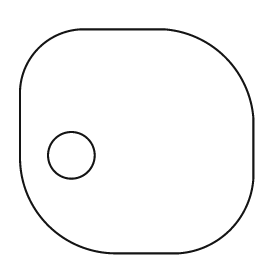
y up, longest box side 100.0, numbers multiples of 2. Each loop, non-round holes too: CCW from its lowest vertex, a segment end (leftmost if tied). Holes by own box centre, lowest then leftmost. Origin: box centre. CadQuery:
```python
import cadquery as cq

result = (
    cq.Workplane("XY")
    .moveTo(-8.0, -48.0)
    .lineTo(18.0, -48.0)
    .threePointArc((40.0, -38.0), (50.0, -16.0))
    .lineTo(50.0, 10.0)
    .threePointArc((38.0, 36.0), (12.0, 48.0))
    .lineTo(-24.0, 48.0)
    .threePointArc((-42.0, 40.0), (-50.0, 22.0))
    .lineTo(-50.0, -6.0)
    .threePointArc((-38.0, -36.0), (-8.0, -48.0))
    .close()
    .moveTo(-28.0, -6.0)
    .circle(10.0)
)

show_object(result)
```